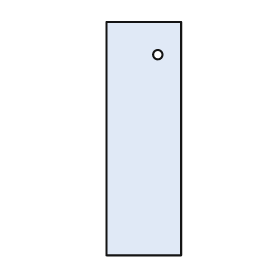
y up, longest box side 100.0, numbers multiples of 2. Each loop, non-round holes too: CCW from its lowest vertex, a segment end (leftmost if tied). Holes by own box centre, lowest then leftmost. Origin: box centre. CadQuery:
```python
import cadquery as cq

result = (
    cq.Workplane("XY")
    .moveTo(-16.0, -50.0)
    .lineTo(16.0, -50.0)
    .lineTo(16.0, 50.0)
    .lineTo(-16.0, 50.0)
    .close()
    .moveTo(6.0, 36.0)
    .circle(2.0)
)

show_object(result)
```